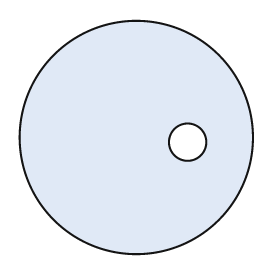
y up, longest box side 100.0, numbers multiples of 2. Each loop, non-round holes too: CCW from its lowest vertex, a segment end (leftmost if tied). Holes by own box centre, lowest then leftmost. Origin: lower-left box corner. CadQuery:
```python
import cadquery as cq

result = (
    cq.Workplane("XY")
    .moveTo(50.0, 50.0)
    .circle(50.0)
    .moveTo(72.0, 48.0)
    .circle(8.0)
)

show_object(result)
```